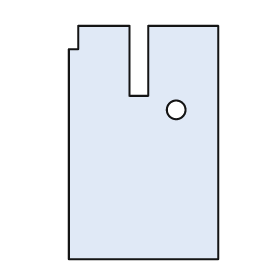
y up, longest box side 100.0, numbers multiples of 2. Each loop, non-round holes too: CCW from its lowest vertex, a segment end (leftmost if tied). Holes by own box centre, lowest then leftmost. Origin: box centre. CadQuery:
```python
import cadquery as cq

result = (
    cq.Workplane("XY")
    .moveTo(-32.0, -50.0)
    .lineTo(32.0, -50.0)
    .lineTo(32.0, 50.0)
    .lineTo(2.0, 50.0)
    .lineTo(2.0, 20.0)
    .lineTo(-6.0, 20.0)
    .lineTo(-6.0, 50.0)
    .lineTo(-28.0, 50.0)
    .lineTo(-28.0, 40.0)
    .lineTo(-32.0, 40.0)
    .close()
    .moveTo(14.0, 14.0)
    .circle(4.0)
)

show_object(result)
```